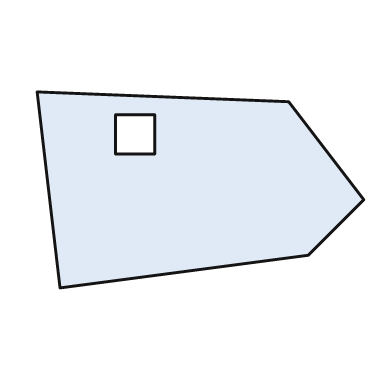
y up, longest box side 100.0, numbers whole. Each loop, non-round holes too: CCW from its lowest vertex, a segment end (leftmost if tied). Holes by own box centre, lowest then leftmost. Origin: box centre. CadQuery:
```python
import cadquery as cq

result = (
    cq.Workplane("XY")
    .moveTo(-43.0, -30.0)
    .lineTo(33.0, -20.0)
    .lineTo(50.0, -3.0)
    .lineTo(27.0, 27.0)
    .lineTo(-50.0, 30.0)
    .close()
    .moveTo(-26.0, 11.0)
    .lineTo(-14.0, 11.0)
    .lineTo(-14.0, 23.0)
    .lineTo(-26.0, 23.0)
    .close()
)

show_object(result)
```